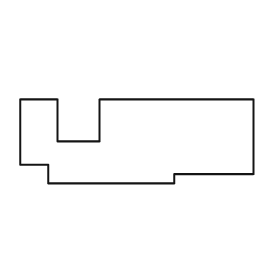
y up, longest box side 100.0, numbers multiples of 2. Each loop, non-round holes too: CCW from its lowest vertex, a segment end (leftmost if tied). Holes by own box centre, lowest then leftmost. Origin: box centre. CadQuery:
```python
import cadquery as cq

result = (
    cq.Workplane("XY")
    .moveTo(-38.0, -18.0)
    .lineTo(16.0, -18.0)
    .lineTo(16.0, -14.0)
    .lineTo(50.0, -14.0)
    .lineTo(50.0, 18.0)
    .lineTo(-16.0, 18.0)
    .lineTo(-16.0, 0.0)
    .lineTo(-34.0, 0.0)
    .lineTo(-34.0, 18.0)
    .lineTo(-50.0, 18.0)
    .lineTo(-50.0, -10.0)
    .lineTo(-38.0, -10.0)
    .close()
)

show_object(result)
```